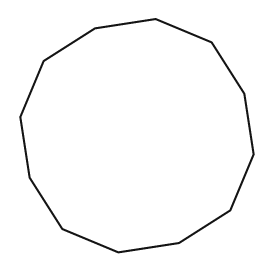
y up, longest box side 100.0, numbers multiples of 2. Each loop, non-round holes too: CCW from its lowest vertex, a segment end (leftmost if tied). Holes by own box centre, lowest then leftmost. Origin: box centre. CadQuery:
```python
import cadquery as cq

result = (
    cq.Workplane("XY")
    .moveTo(-8.0, -50.0)
    .lineTo(18.0, -46.0)
    .lineTo(40.0, -32.0)
    .lineTo(50.0, -8.0)
    .lineTo(46.0, 18.0)
    .lineTo(32.0, 40.0)
    .lineTo(8.0, 50.0)
    .lineTo(-18.0, 46.0)
    .lineTo(-40.0, 32.0)
    .lineTo(-50.0, 8.0)
    .lineTo(-46.0, -18.0)
    .lineTo(-32.0, -40.0)
    .close()
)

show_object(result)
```